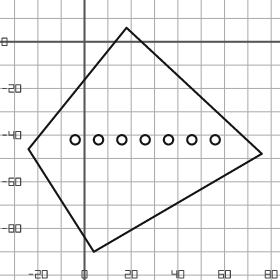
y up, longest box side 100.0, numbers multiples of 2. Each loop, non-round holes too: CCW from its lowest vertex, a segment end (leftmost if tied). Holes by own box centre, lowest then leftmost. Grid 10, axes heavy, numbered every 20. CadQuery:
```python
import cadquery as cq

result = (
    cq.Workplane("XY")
    .moveTo(4.0, -90.0)
    .lineTo(76.0, -48.0)
    .lineTo(18.0, 6.0)
    .lineTo(-24.0, -46.0)
    .close()
    .moveTo(-4.0, -42.0)
    .circle(2.0)
    .moveTo(6.0, -42.0)
    .circle(2.0)
    .moveTo(16.0, -42.0)
    .circle(2.0)
    .moveTo(26.0, -42.0)
    .circle(2.0)
    .moveTo(36.0, -42.0)
    .circle(2.0)
    .moveTo(46.0, -42.0)
    .circle(2.0)
    .moveTo(56.0, -42.0)
    .circle(2.0)
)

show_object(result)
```